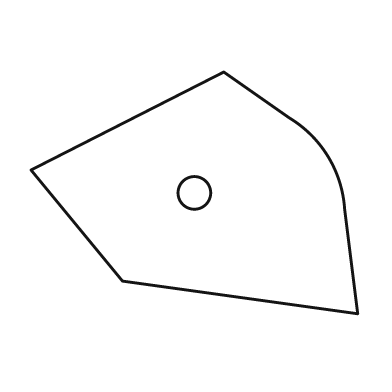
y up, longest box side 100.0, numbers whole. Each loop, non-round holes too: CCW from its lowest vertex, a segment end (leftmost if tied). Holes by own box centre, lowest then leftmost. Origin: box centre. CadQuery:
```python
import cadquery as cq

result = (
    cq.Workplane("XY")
    .moveTo(50.0, -37.0)
    .lineTo(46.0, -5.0)
    .threePointArc((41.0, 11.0), (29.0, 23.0))
    .lineTo(9.0, 37.0)
    .lineTo(-50.0, 7.0)
    .lineTo(-22.0, -27.0)
    .close()
    .moveTo(0.0, 0.0)
    .circle(5.0)
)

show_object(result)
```